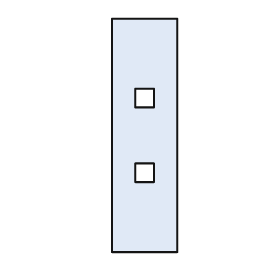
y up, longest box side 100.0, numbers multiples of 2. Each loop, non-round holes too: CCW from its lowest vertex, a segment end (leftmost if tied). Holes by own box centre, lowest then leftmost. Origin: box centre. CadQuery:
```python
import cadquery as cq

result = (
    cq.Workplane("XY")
    .moveTo(-14.0, -50.0)
    .lineTo(14.0, -50.0)
    .lineTo(14.0, 50.0)
    .lineTo(-14.0, 50.0)
    .close()
    .moveTo(-4.0, -20.0)
    .lineTo(4.0, -20.0)
    .lineTo(4.0, -12.0)
    .lineTo(-4.0, -12.0)
    .close()
    .moveTo(-4.0, 12.0)
    .lineTo(4.0, 12.0)
    .lineTo(4.0, 20.0)
    .lineTo(-4.0, 20.0)
    .close()
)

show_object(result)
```